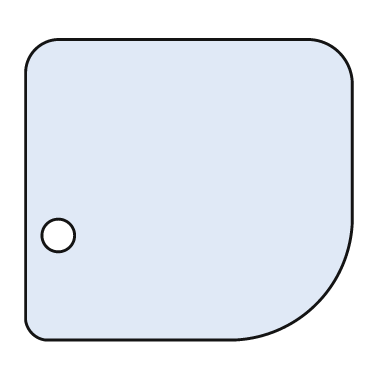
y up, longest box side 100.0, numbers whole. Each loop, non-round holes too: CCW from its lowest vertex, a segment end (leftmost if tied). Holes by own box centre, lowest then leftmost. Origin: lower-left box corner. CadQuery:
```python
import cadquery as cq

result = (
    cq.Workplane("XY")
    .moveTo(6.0, 0.0)
    .lineTo(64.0, 0.0)
    .threePointArc((89.0, 11.0), (100.0, 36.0))
    .lineTo(100.0, 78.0)
    .threePointArc((96.0, 88.0), (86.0, 92.0))
    .lineTo(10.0, 92.0)
    .threePointArc((3.0, 89.0), (0.0, 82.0))
    .lineTo(0.0, 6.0)
    .threePointArc((2.0, 2.0), (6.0, 0.0))
    .close()
    .moveTo(10.0, 32.0)
    .circle(5.0)
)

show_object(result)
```